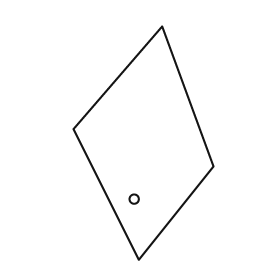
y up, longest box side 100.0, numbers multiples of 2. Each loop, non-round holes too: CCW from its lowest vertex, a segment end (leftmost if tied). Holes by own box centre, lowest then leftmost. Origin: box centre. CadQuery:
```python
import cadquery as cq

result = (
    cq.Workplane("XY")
    .moveTo(-2.0, -50.0)
    .lineTo(30.0, -10.0)
    .lineTo(8.0, 50.0)
    .lineTo(-30.0, 6.0)
    .close()
    .moveTo(-4.0, -24.0)
    .circle(2.0)
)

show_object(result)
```